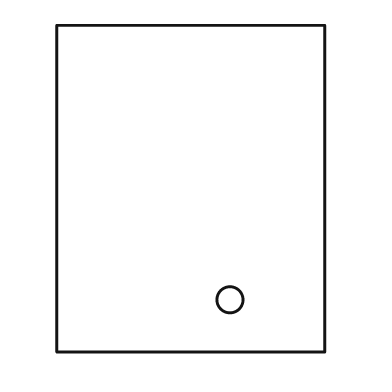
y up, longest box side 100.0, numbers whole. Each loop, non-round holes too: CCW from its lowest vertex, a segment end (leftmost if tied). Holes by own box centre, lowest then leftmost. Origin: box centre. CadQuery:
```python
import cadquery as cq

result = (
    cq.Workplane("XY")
    .moveTo(-41.0, -50.0)
    .lineTo(41.0, -50.0)
    .lineTo(41.0, 50.0)
    .lineTo(-41.0, 50.0)
    .close()
    .moveTo(12.0, -34.0)
    .circle(4.0)
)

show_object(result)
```